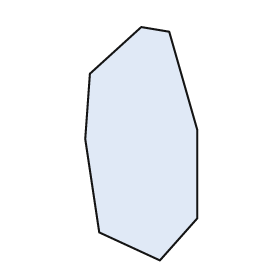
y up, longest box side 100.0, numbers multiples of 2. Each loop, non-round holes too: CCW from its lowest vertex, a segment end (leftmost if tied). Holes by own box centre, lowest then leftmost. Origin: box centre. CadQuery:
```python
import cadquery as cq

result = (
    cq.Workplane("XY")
    .moveTo(8.0, -50.0)
    .lineTo(24.0, -32.0)
    .lineTo(24.0, 6.0)
    .lineTo(12.0, 48.0)
    .lineTo(0.0, 50.0)
    .lineTo(-22.0, 30.0)
    .lineTo(-24.0, 2.0)
    .lineTo(-18.0, -38.0)
    .close()
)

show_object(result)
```